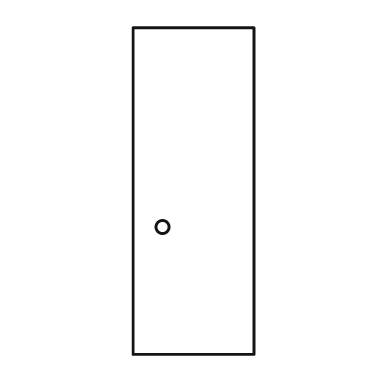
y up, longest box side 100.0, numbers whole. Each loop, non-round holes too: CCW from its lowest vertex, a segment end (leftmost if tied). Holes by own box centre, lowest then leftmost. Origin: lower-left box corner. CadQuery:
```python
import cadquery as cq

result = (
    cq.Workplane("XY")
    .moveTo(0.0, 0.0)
    .lineTo(37.0, 0.0)
    .lineTo(37.0, 100.0)
    .lineTo(0.0, 100.0)
    .close()
    .moveTo(9.0, 39.0)
    .circle(2.0)
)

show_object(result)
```